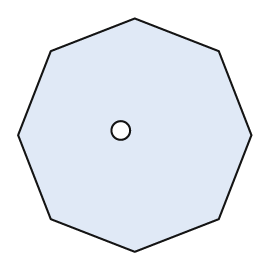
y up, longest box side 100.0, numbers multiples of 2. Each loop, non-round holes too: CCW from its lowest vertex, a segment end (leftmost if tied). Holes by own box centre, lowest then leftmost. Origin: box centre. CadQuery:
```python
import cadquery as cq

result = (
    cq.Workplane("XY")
    .moveTo(0.0, -50.0)
    .lineTo(36.0, -36.0)
    .lineTo(50.0, 0.0)
    .lineTo(36.0, 36.0)
    .lineTo(0.0, 50.0)
    .lineTo(-36.0, 36.0)
    .lineTo(-50.0, 0.0)
    .lineTo(-36.0, -36.0)
    .close()
    .moveTo(-6.0, 2.0)
    .circle(4.0)
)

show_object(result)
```